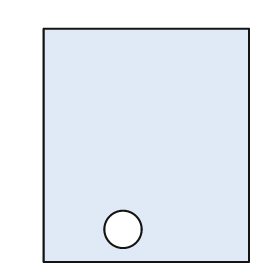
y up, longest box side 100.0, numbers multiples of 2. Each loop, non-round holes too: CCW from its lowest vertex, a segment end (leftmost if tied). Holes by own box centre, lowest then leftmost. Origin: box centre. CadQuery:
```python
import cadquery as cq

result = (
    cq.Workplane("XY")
    .moveTo(-44.0, -50.0)
    .lineTo(44.0, -50.0)
    .lineTo(44.0, 50.0)
    .lineTo(-44.0, 50.0)
    .close()
    .moveTo(-10.0, -36.0)
    .circle(8.0)
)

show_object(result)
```